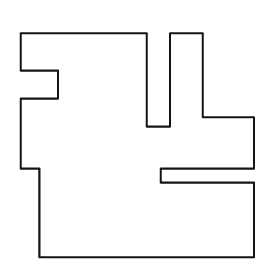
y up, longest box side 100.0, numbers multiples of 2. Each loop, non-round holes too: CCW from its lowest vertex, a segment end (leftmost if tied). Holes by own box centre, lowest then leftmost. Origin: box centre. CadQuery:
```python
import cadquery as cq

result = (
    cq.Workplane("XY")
    .moveTo(-42.0, -48.0)
    .lineTo(50.0, -48.0)
    .lineTo(50.0, -16.0)
    .lineTo(10.0, -16.0)
    .lineTo(10.0, -10.0)
    .lineTo(50.0, -10.0)
    .lineTo(50.0, 12.0)
    .lineTo(28.0, 12.0)
    .lineTo(28.0, 48.0)
    .lineTo(14.0, 48.0)
    .lineTo(14.0, 8.0)
    .lineTo(4.0, 8.0)
    .lineTo(4.0, 48.0)
    .lineTo(-50.0, 48.0)
    .lineTo(-50.0, 32.0)
    .lineTo(-34.0, 32.0)
    .lineTo(-34.0, 20.0)
    .lineTo(-50.0, 20.0)
    .lineTo(-50.0, -10.0)
    .lineTo(-42.0, -10.0)
    .close()
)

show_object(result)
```